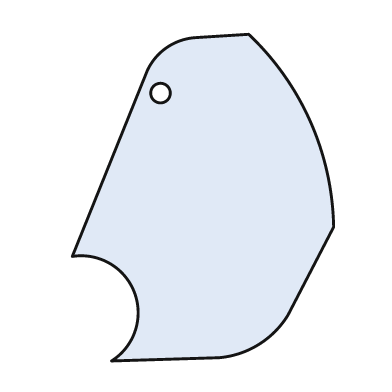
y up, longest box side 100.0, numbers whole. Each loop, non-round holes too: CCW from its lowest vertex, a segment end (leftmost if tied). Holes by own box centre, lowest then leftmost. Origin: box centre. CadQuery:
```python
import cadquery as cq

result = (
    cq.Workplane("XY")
    .moveTo(-28.0, -50.0)
    .lineTo(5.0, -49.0)
    .threePointArc((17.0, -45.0), (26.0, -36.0))
    .lineTo(40.0, -9.0)
    .threePointArc((33.0, 23.0), (14.0, 50.0))
    .lineTo(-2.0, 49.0)
    .threePointArc((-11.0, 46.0), (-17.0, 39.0))
    .lineTo(-40.0, -18.0)
    .threePointArc((-21.0, -29.0), (-28.0, -50.0))
    .close()
    .moveTo(-13.0, 32.0)
    .circle(3.0)
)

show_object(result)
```